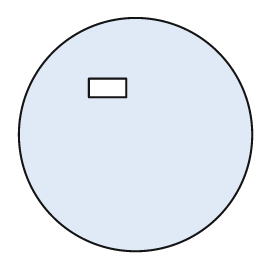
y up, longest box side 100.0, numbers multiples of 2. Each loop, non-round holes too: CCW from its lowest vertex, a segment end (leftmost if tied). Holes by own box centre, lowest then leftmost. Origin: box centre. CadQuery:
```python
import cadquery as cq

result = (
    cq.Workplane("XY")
    .moveTo(0.0, 0.0)
    .circle(50.0)
    .moveTo(-20.0, 16.0)
    .lineTo(-4.0, 16.0)
    .lineTo(-4.0, 24.0)
    .lineTo(-20.0, 24.0)
    .close()
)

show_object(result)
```